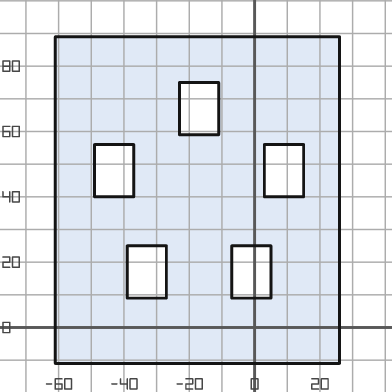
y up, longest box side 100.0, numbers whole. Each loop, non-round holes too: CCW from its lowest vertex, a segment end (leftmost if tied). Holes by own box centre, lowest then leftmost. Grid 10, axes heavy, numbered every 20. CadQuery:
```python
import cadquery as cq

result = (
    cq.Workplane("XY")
    .moveTo(-61.0, -11.0)
    .lineTo(26.0, -11.0)
    .lineTo(26.0, 89.0)
    .lineTo(-61.0, 89.0)
    .close()
    .moveTo(-39.0, 9.0)
    .lineTo(-27.0, 9.0)
    .lineTo(-27.0, 25.0)
    .lineTo(-39.0, 25.0)
    .close()
    .moveTo(-7.0, 9.0)
    .lineTo(5.0, 9.0)
    .lineTo(5.0, 25.0)
    .lineTo(-7.0, 25.0)
    .close()
    .moveTo(-49.0, 40.0)
    .lineTo(-37.0, 40.0)
    .lineTo(-37.0, 56.0)
    .lineTo(-49.0, 56.0)
    .close()
    .moveTo(3.0, 40.0)
    .lineTo(15.0, 40.0)
    .lineTo(15.0, 56.0)
    .lineTo(3.0, 56.0)
    .close()
    .moveTo(-23.0, 59.0)
    .lineTo(-11.0, 59.0)
    .lineTo(-11.0, 75.0)
    .lineTo(-23.0, 75.0)
    .close()
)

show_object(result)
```